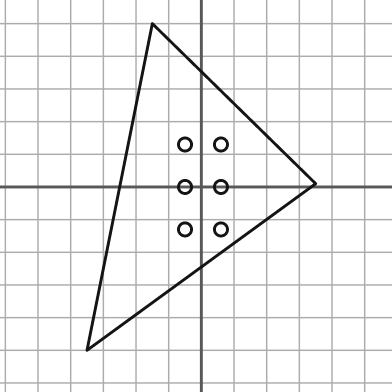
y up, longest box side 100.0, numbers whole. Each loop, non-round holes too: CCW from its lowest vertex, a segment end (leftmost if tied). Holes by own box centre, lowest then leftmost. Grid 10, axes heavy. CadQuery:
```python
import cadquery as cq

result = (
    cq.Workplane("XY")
    .moveTo(-35.0, -50.0)
    .lineTo(35.0, 1.0)
    .lineTo(-15.0, 50.0)
    .close()
    .moveTo(-5.0, -13.0)
    .circle(2.0)
    .moveTo(6.0, -13.0)
    .circle(2.0)
    .moveTo(-5.0, 0.0)
    .circle(2.0)
    .moveTo(6.0, 0.0)
    .circle(2.0)
    .moveTo(-5.0, 13.0)
    .circle(2.0)
    .moveTo(6.0, 13.0)
    .circle(2.0)
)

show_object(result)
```